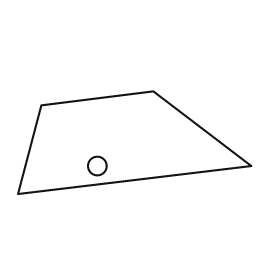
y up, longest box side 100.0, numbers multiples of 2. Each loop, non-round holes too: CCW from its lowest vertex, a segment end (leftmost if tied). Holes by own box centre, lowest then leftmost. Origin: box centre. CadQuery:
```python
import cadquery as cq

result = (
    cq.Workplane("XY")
    .moveTo(-50.0, -22.0)
    .lineTo(50.0, -10.0)
    .lineTo(8.0, 22.0)
    .lineTo(-40.0, 16.0)
    .close()
    .moveTo(-16.0, -10.0)
    .circle(4.0)
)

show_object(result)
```